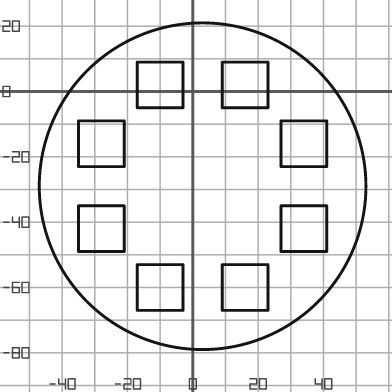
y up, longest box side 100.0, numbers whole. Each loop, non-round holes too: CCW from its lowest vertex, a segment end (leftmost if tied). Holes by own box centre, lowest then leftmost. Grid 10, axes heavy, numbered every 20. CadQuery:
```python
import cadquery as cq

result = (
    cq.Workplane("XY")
    .moveTo(3.0, -29.0)
    .circle(50.0)
    .moveTo(-17.0, -67.0)
    .lineTo(-3.0, -67.0)
    .lineTo(-3.0, -53.0)
    .lineTo(-17.0, -53.0)
    .close()
    .moveTo(9.0, -67.0)
    .lineTo(23.0, -67.0)
    .lineTo(23.0, -53.0)
    .lineTo(9.0, -53.0)
    .close()
    .moveTo(-35.0, -49.0)
    .lineTo(-21.0, -49.0)
    .lineTo(-21.0, -35.0)
    .lineTo(-35.0, -35.0)
    .close()
    .moveTo(27.0, -49.0)
    .lineTo(41.0, -49.0)
    .lineTo(41.0, -35.0)
    .lineTo(27.0, -35.0)
    .close()
    .moveTo(-35.0, -23.0)
    .lineTo(-21.0, -23.0)
    .lineTo(-21.0, -9.0)
    .lineTo(-35.0, -9.0)
    .close()
    .moveTo(27.0, -23.0)
    .lineTo(41.0, -23.0)
    .lineTo(41.0, -9.0)
    .lineTo(27.0, -9.0)
    .close()
    .moveTo(-17.0, -5.0)
    .lineTo(-3.0, -5.0)
    .lineTo(-3.0, 9.0)
    .lineTo(-17.0, 9.0)
    .close()
    .moveTo(9.0, -5.0)
    .lineTo(23.0, -5.0)
    .lineTo(23.0, 9.0)
    .lineTo(9.0, 9.0)
    .close()
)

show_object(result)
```